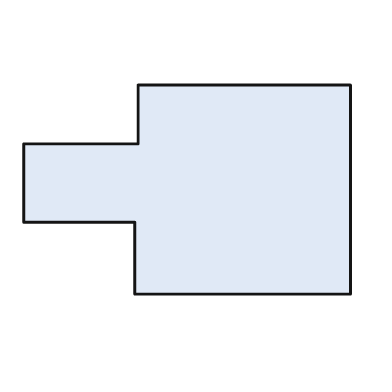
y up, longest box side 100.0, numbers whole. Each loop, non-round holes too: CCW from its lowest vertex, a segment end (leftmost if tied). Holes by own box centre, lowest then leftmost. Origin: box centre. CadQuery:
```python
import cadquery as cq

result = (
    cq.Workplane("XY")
    .moveTo(-16.0, -32.0)
    .lineTo(50.0, -32.0)
    .lineTo(50.0, 32.0)
    .lineTo(-15.0, 32.0)
    .lineTo(-15.0, 14.0)
    .lineTo(-50.0, 14.0)
    .lineTo(-50.0, -10.0)
    .lineTo(-16.0, -10.0)
    .close()
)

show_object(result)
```